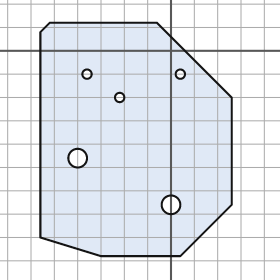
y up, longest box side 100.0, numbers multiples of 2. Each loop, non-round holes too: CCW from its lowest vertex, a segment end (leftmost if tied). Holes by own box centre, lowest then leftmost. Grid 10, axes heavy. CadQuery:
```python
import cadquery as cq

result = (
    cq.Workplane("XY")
    .moveTo(-30.0, -88.0)
    .lineTo(4.0, -88.0)
    .lineTo(26.0, -66.0)
    .lineTo(26.0, -20.0)
    .lineTo(-6.0, 12.0)
    .lineTo(-52.0, 12.0)
    .lineTo(-56.0, 8.0)
    .lineTo(-56.0, -80.0)
    .close()
    .moveTo(0.0, -66.0)
    .circle(4.0)
    .moveTo(-40.0, -46.0)
    .circle(4.0)
    .moveTo(-22.0, -20.0)
    .circle(2.0)
    .moveTo(-36.0, -10.0)
    .circle(2.0)
    .moveTo(4.0, -10.0)
    .circle(2.0)
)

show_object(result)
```